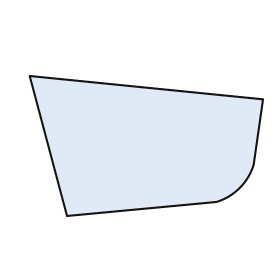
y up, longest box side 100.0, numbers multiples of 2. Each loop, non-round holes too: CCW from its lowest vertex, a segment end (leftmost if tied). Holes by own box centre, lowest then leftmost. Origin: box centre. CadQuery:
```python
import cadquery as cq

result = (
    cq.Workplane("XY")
    .moveTo(-34.0, -30.0)
    .lineTo(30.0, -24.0)
    .threePointArc((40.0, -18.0), (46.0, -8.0))
    .lineTo(50.0, 20.0)
    .lineTo(-50.0, 30.0)
    .close()
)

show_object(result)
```